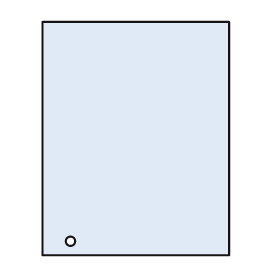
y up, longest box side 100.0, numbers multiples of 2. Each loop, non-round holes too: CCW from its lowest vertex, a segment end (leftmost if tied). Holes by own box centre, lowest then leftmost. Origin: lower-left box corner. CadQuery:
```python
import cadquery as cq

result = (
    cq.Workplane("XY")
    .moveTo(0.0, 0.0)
    .lineTo(80.0, 0.0)
    .lineTo(80.0, 100.0)
    .lineTo(0.0, 100.0)
    .close()
    .moveTo(12.0, 6.0)
    .circle(2.0)
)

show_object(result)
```